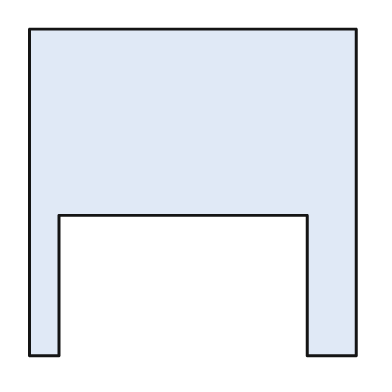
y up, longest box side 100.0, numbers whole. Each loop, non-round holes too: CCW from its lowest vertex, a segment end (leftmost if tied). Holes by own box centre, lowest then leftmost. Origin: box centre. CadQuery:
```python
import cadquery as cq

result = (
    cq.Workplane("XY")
    .moveTo(-50.0, -50.0)
    .lineTo(-41.0, -50.0)
    .lineTo(-41.0, -7.0)
    .lineTo(35.0, -7.0)
    .lineTo(35.0, -50.0)
    .lineTo(50.0, -50.0)
    .lineTo(50.0, 50.0)
    .lineTo(-50.0, 50.0)
    .close()
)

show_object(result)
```